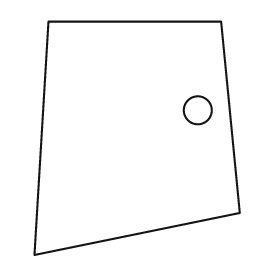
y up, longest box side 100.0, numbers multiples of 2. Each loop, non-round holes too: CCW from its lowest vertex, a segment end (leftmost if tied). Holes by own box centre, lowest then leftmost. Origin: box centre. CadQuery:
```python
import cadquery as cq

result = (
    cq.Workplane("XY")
    .moveTo(-44.0, -50.0)
    .lineTo(44.0, -32.0)
    .lineTo(36.0, 50.0)
    .lineTo(-38.0, 50.0)
    .close()
    .moveTo(26.0, 12.0)
    .circle(6.0)
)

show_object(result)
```